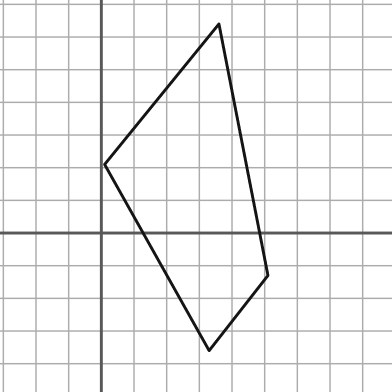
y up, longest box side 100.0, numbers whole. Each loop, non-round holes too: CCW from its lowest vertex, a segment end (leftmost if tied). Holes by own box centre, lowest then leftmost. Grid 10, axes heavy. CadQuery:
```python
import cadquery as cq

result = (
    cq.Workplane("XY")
    .moveTo(33.0, -36.0)
    .lineTo(51.0, -13.0)
    .lineTo(36.0, 64.0)
    .lineTo(1.0, 21.0)
    .close()
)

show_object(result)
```